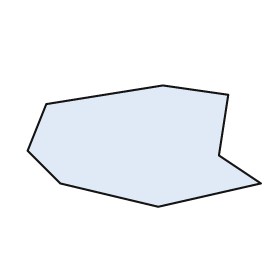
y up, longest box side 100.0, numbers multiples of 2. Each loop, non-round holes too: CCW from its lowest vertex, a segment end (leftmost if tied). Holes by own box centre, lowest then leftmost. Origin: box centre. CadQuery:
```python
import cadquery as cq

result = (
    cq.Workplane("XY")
    .moveTo(6.0, -26.0)
    .lineTo(50.0, -16.0)
    .lineTo(32.0, -4.0)
    .lineTo(36.0, 22.0)
    .lineTo(8.0, 26.0)
    .lineTo(-42.0, 18.0)
    .lineTo(-50.0, -2.0)
    .lineTo(-36.0, -16.0)
    .close()
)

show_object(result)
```